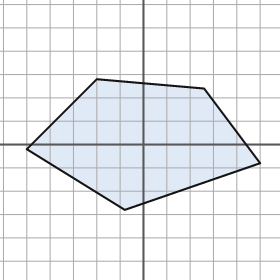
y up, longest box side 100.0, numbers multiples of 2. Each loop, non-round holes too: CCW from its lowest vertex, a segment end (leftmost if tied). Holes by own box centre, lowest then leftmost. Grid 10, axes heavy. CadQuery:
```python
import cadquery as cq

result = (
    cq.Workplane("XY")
    .moveTo(-8.0, -28.0)
    .lineTo(50.0, -8.0)
    .lineTo(26.0, 24.0)
    .lineTo(-20.0, 28.0)
    .lineTo(-50.0, -2.0)
    .close()
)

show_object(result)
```